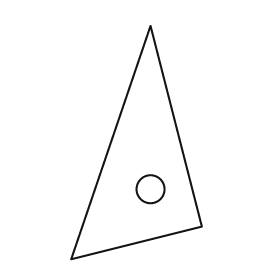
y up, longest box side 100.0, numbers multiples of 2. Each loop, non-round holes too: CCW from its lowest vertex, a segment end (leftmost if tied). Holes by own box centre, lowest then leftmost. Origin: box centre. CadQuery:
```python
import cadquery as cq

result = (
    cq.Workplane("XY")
    .moveTo(-28.0, -50.0)
    .lineTo(28.0, -36.0)
    .lineTo(6.0, 50.0)
    .close()
    .moveTo(6.0, -20.0)
    .circle(6.0)
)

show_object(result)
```